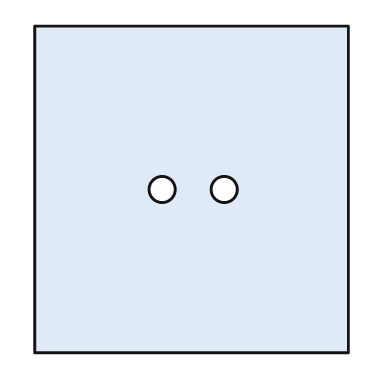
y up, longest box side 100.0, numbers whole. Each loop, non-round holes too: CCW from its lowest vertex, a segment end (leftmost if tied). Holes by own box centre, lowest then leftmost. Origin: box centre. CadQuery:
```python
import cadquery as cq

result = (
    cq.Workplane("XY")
    .moveTo(-48.0, -50.0)
    .lineTo(48.0, -50.0)
    .lineTo(48.0, 50.0)
    .lineTo(-48.0, 50.0)
    .close()
    .moveTo(-9.0, 0.0)
    .circle(4.0)
    .moveTo(10.0, 0.0)
    .circle(4.0)
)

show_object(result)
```